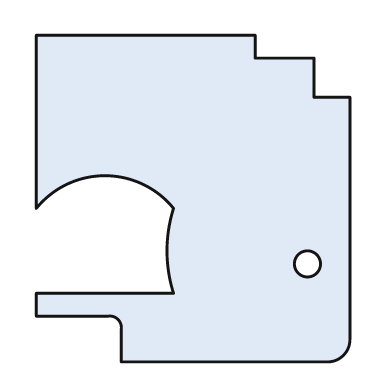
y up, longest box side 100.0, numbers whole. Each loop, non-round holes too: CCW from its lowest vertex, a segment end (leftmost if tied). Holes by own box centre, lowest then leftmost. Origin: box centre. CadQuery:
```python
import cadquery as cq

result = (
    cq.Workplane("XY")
    .moveTo(-22.0, -50.0)
    .lineTo(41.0, -50.0)
    .threePointArc((46.0, -48.0), (48.0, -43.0))
    .lineTo(48.0, 31.0)
    .lineTo(37.0, 31.0)
    .lineTo(37.0, 43.0)
    .lineTo(19.0, 43.0)
    .lineTo(19.0, 50.0)
    .lineTo(-48.0, 50.0)
    .lineTo(-48.0, -3.0)
    .threePointArc((-27.0, 7.0), (-6.0, -3.0))
    .threePointArc((-8.0, -16.0), (-6.0, -29.0))
    .lineTo(-48.0, -29.0)
    .lineTo(-48.0, -36.0)
    .lineTo(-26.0, -36.0)
    .threePointArc((-23.0, -37.0), (-22.0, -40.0))
    .close()
    .moveTo(35.0, -20.0)
    .circle(4.0)
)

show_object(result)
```